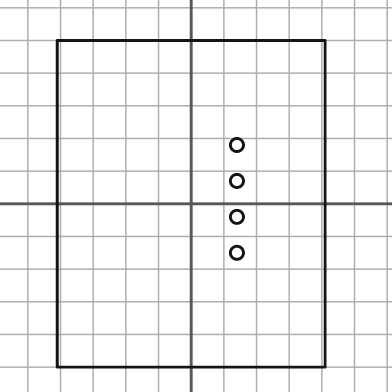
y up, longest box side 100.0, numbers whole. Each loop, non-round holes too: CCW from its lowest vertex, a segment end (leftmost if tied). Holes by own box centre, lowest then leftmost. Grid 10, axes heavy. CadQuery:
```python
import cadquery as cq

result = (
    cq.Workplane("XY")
    .moveTo(-41.0, -50.0)
    .lineTo(41.0, -50.0)
    .lineTo(41.0, 50.0)
    .lineTo(-41.0, 50.0)
    .close()
    .moveTo(14.0, -15.0)
    .circle(2.0)
    .moveTo(14.0, -4.0)
    .circle(2.0)
    .moveTo(14.0, 7.0)
    .circle(2.0)
    .moveTo(14.0, 18.0)
    .circle(2.0)
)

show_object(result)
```